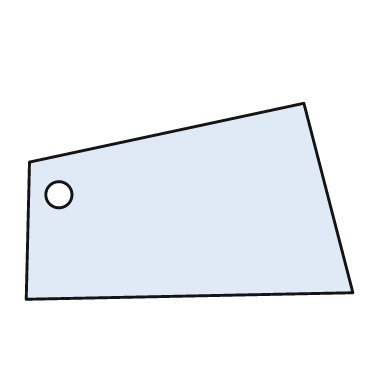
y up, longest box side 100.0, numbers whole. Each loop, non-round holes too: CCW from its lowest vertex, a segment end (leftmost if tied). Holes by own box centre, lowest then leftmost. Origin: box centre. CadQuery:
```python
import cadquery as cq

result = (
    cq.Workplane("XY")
    .moveTo(-50.0, -30.0)
    .lineTo(50.0, -28.0)
    .lineTo(35.0, 30.0)
    .lineTo(-49.0, 12.0)
    .close()
    .moveTo(-40.0, 2.0)
    .circle(4.0)
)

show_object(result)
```